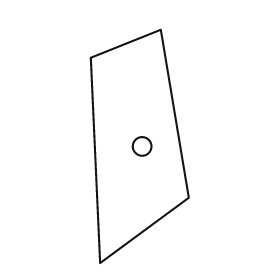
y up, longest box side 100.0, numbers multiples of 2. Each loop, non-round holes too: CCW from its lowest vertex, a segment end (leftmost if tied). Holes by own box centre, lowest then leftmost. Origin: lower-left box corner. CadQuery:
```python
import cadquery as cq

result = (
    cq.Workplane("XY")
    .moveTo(4.0, 0.0)
    .lineTo(42.0, 28.0)
    .lineTo(30.0, 100.0)
    .lineTo(0.0, 88.0)
    .close()
    .moveTo(22.0, 50.0)
    .circle(4.0)
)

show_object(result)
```